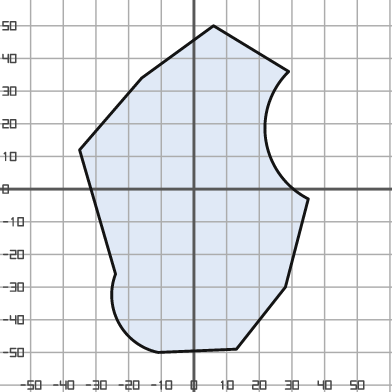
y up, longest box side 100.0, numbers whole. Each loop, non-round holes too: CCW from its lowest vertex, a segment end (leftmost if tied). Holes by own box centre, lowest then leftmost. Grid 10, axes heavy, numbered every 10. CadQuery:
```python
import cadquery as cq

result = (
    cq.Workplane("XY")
    .moveTo(-11.0, -50.0)
    .lineTo(13.0, -49.0)
    .lineTo(28.0, -30.0)
    .lineTo(35.0, -3.0)
    .threePointArc((22.0, 15.0), (29.0, 36.0))
    .lineTo(6.0, 50.0)
    .lineTo(-16.0, 34.0)
    .lineTo(-35.0, 12.0)
    .lineTo(-24.0, -26.0)
    .threePointArc((-23.0, -41.0), (-11.0, -50.0))
    .close()
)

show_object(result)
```